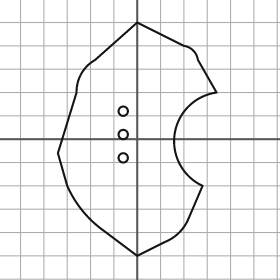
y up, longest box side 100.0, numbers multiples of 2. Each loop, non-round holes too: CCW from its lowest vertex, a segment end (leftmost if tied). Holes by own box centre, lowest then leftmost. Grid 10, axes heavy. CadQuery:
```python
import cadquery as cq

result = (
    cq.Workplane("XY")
    .moveTo(0.0, -50.0)
    .lineTo(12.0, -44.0)
    .threePointArc((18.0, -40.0), (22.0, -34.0))
    .lineTo(28.0, -20.0)
    .threePointArc((16.0, 2.0), (34.0, 20.0))
    .lineTo(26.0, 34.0)
    .threePointArc((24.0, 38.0), (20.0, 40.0))
    .lineTo(0.0, 50.0)
    .lineTo(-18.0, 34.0)
    .threePointArc((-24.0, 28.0), (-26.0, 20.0))
    .lineTo(-34.0, -6.0)
    .lineTo(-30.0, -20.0)
    .threePointArc((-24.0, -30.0), (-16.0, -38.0))
    .close()
    .moveTo(-6.0, -8.0)
    .circle(2.0)
    .moveTo(-6.0, 2.0)
    .circle(2.0)
    .moveTo(-6.0, 12.0)
    .circle(2.0)
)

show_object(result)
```